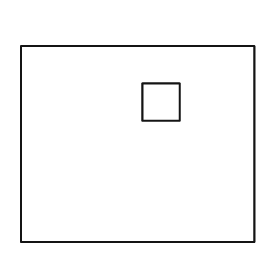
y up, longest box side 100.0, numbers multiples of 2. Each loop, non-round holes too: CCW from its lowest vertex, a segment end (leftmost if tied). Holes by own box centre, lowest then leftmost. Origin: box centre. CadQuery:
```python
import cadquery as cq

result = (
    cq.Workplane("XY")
    .moveTo(-50.0, -42.0)
    .lineTo(50.0, -42.0)
    .lineTo(50.0, 42.0)
    .lineTo(-50.0, 42.0)
    .close()
    .moveTo(2.0, 10.0)
    .lineTo(18.0, 10.0)
    .lineTo(18.0, 26.0)
    .lineTo(2.0, 26.0)
    .close()
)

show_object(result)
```